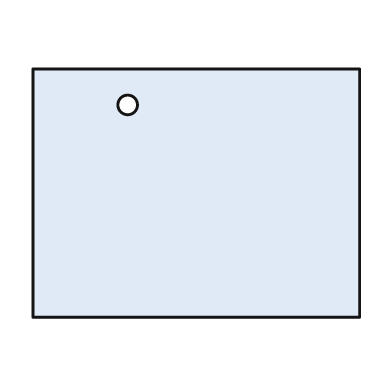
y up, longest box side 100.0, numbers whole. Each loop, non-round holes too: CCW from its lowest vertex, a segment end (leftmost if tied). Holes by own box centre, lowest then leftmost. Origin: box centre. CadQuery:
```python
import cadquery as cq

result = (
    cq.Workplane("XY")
    .moveTo(-50.0, -38.0)
    .lineTo(50.0, -38.0)
    .lineTo(50.0, 38.0)
    .lineTo(-50.0, 38.0)
    .close()
    .moveTo(-21.0, 27.0)
    .circle(3.0)
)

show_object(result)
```